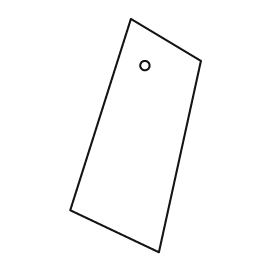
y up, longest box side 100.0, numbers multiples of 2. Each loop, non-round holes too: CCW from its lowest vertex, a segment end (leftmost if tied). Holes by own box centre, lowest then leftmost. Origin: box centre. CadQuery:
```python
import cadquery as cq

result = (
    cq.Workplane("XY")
    .moveTo(10.0, -50.0)
    .lineTo(28.0, 32.0)
    .lineTo(-2.0, 50.0)
    .lineTo(-28.0, -32.0)
    .close()
    .moveTo(4.0, 30.0)
    .circle(2.0)
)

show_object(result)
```